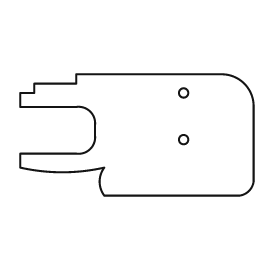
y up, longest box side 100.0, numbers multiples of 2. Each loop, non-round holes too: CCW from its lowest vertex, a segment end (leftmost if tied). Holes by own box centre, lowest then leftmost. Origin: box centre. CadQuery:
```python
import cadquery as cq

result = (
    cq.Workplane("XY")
    .moveTo(-14.0, -26.0)
    .lineTo(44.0, -26.0)
    .threePointArc((48.0, -24.0), (50.0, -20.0))
    .lineTo(50.0, 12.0)
    .threePointArc((46.0, 22.0), (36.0, 26.0))
    .lineTo(-26.0, 26.0)
    .lineTo(-26.0, 22.0)
    .lineTo(-44.0, 22.0)
    .lineTo(-44.0, 18.0)
    .lineTo(-50.0, 18.0)
    .lineTo(-50.0, 12.0)
    .lineTo(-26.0, 12.0)
    .threePointArc((-20.0, 10.0), (-18.0, 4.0))
    .lineTo(-18.0, 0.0)
    .threePointArc((-20.0, -6.0), (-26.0, -8.0))
    .lineTo(-50.0, -8.0)
    .lineTo(-50.0, -14.0)
    .threePointArc((-32.0, -16.0), (-14.0, -14.0))
    .threePointArc((-16.0, -20.0), (-14.0, -26.0))
    .close()
    .moveTo(20.0, -2.0)
    .circle(2.0)
    .moveTo(20.0, 18.0)
    .circle(2.0)
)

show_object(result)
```